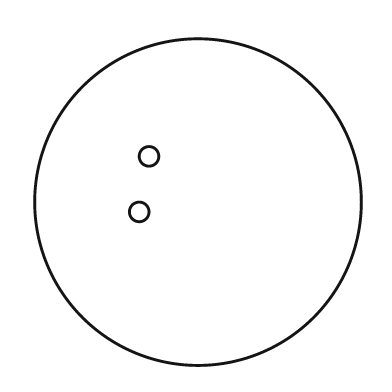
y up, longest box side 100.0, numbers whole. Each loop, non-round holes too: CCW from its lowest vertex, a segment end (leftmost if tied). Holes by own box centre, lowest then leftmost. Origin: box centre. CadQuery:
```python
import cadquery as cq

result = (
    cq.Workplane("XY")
    .moveTo(0.0, 0.0)
    .circle(50.0)
    .moveTo(-18.0, -3.0)
    .circle(3.0)
    .moveTo(-15.0, 14.0)
    .circle(3.0)
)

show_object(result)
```